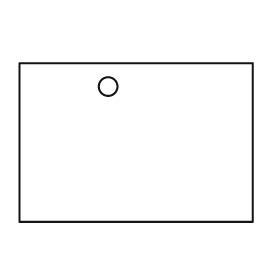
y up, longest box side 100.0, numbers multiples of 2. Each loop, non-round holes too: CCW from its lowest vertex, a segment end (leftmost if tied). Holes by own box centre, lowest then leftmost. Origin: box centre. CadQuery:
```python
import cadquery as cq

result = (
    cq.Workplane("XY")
    .moveTo(-50.0, -34.0)
    .lineTo(50.0, -34.0)
    .lineTo(50.0, 34.0)
    .lineTo(-50.0, 34.0)
    .close()
    .moveTo(-12.0, 24.0)
    .circle(4.0)
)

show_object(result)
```